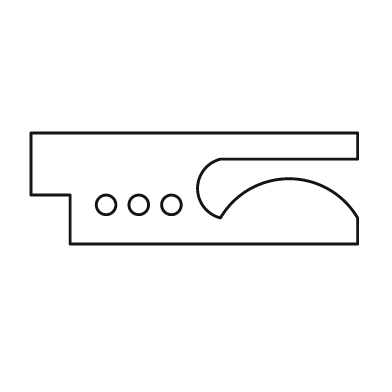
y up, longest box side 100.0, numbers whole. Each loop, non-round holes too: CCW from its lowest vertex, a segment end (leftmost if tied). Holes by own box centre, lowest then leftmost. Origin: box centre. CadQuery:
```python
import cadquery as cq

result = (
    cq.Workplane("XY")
    .moveTo(-38.0, -17.0)
    .lineTo(50.0, -17.0)
    .lineTo(50.0, -9.0)
    .threePointArc((29.0, 3.0), (8.0, -9.0))
    .threePointArc((1.0, 0.0), (8.0, 9.0))
    .lineTo(50.0, 9.0)
    .lineTo(50.0, 17.0)
    .lineTo(-50.0, 17.0)
    .lineTo(-50.0, -2.0)
    .lineTo(-38.0, -2.0)
    .close()
    .moveTo(-27.0, -5.0)
    .circle(3.0)
    .moveTo(-17.0, -5.0)
    .circle(3.0)
    .moveTo(-7.0, -5.0)
    .circle(3.0)
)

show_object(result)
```